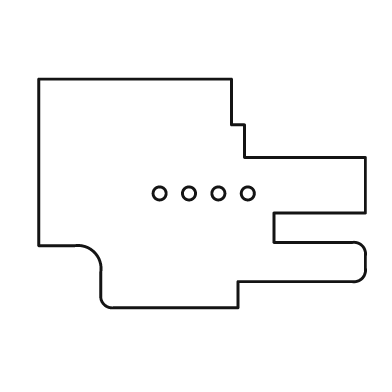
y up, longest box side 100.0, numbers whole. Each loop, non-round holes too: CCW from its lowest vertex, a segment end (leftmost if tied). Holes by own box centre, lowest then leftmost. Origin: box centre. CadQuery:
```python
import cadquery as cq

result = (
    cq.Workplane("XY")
    .moveTo(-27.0, -35.0)
    .lineTo(11.0, -35.0)
    .lineTo(11.0, -27.0)
    .lineTo(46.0, -27.0)
    .threePointArc((49.0, -26.0), (50.0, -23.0))
    .lineTo(50.0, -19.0)
    .threePointArc((49.0, -16.0), (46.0, -15.0))
    .lineTo(22.0, -15.0)
    .lineTo(22.0, -6.0)
    .lineTo(50.0, -6.0)
    .lineTo(50.0, 11.0)
    .lineTo(13.0, 11.0)
    .lineTo(13.0, 21.0)
    .lineTo(9.0, 21.0)
    .lineTo(9.0, 35.0)
    .lineTo(-50.0, 35.0)
    .lineTo(-50.0, -16.0)
    .lineTo(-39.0, -16.0)
    .threePointArc((-33.0, -18.0), (-31.0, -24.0))
    .lineTo(-31.0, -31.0)
    .threePointArc((-30.0, -34.0), (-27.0, -35.0))
    .close()
    .moveTo(-13.0, 0.0)
    .circle(2.0)
    .moveTo(-4.0, 0.0)
    .circle(2.0)
    .moveTo(5.0, 0.0)
    .circle(2.0)
    .moveTo(14.0, 0.0)
    .circle(2.0)
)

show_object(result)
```